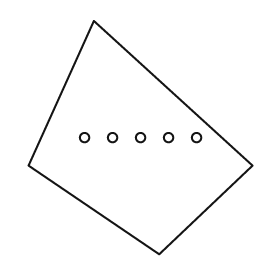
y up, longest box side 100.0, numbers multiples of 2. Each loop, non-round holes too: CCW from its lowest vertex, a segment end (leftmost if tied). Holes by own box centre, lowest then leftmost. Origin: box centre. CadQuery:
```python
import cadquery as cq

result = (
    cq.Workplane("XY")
    .moveTo(8.0, -50.0)
    .lineTo(48.0, -12.0)
    .lineTo(-20.0, 50.0)
    .lineTo(-48.0, -12.0)
    .close()
    .moveTo(-24.0, 0.0)
    .circle(2.0)
    .moveTo(-12.0, 0.0)
    .circle(2.0)
    .moveTo(0.0, 0.0)
    .circle(2.0)
    .moveTo(12.0, 0.0)
    .circle(2.0)
    .moveTo(24.0, 0.0)
    .circle(2.0)
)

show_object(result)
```